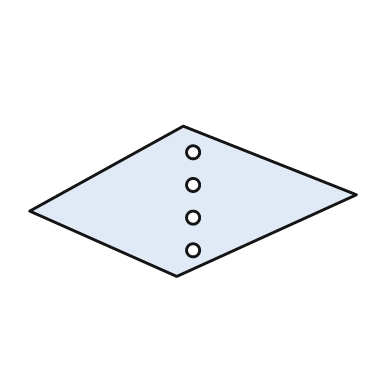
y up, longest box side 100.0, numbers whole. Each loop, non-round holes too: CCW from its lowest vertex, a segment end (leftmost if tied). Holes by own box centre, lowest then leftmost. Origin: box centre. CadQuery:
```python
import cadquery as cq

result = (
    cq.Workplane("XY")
    .moveTo(-5.0, -23.0)
    .lineTo(50.0, 2.0)
    .lineTo(-3.0, 23.0)
    .lineTo(-50.0, -3.0)
    .close()
    .moveTo(0.0, -15.0)
    .circle(2.0)
    .moveTo(0.0, -5.0)
    .circle(2.0)
    .moveTo(0.0, 5.0)
    .circle(2.0)
    .moveTo(0.0, 15.0)
    .circle(2.0)
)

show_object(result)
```